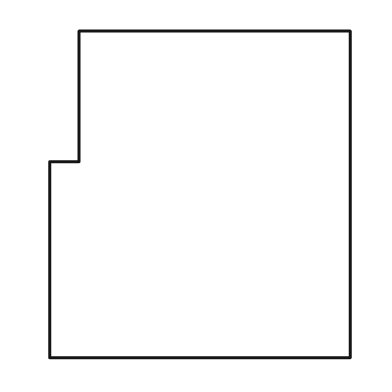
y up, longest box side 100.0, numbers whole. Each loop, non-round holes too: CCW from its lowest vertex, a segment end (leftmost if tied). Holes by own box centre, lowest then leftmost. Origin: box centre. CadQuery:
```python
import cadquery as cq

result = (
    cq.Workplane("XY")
    .moveTo(-46.0, -50.0)
    .lineTo(46.0, -50.0)
    .lineTo(46.0, 50.0)
    .lineTo(-37.0, 50.0)
    .lineTo(-37.0, 10.0)
    .lineTo(-46.0, 10.0)
    .close()
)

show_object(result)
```